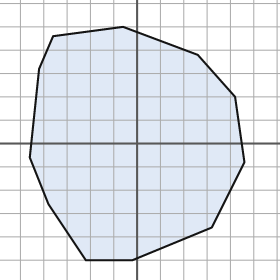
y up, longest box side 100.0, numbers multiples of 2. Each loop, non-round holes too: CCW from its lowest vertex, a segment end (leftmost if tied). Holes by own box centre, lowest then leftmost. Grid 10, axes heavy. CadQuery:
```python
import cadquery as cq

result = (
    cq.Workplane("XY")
    .moveTo(-22.0, -50.0)
    .lineTo(-2.0, -50.0)
    .lineTo(32.0, -36.0)
    .lineTo(46.0, -8.0)
    .lineTo(42.0, 20.0)
    .lineTo(26.0, 38.0)
    .lineTo(-6.0, 50.0)
    .lineTo(-36.0, 46.0)
    .lineTo(-42.0, 32.0)
    .lineTo(-46.0, -6.0)
    .lineTo(-38.0, -26.0)
    .close()
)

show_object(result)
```